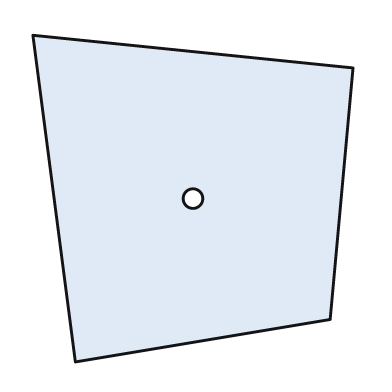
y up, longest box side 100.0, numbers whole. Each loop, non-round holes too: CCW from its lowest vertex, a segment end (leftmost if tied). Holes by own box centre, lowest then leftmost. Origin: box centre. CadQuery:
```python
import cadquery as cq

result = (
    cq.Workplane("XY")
    .moveTo(-36.0, -50.0)
    .lineTo(42.0, -37.0)
    .lineTo(49.0, 40.0)
    .lineTo(-49.0, 50.0)
    .close()
    .moveTo(0.0, 0.0)
    .circle(3.0)
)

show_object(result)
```